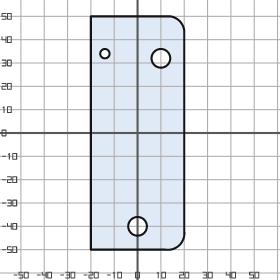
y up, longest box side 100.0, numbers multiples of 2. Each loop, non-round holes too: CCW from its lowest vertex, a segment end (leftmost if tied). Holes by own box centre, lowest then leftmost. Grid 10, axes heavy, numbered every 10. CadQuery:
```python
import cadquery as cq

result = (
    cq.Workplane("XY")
    .moveTo(-20.0, -50.0)
    .lineTo(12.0, -50.0)
    .threePointArc((18.0, -48.0), (20.0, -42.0))
    .lineTo(20.0, 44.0)
    .threePointArc((18.0, 48.0), (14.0, 50.0))
    .lineTo(-20.0, 50.0)
    .close()
    .moveTo(0.0, -40.0)
    .circle(4.0)
    .moveTo(10.0, 32.0)
    .circle(4.0)
    .moveTo(-14.0, 34.0)
    .circle(2.0)
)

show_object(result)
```